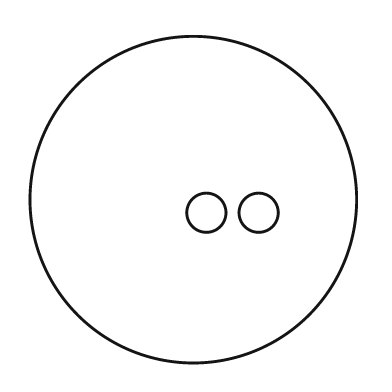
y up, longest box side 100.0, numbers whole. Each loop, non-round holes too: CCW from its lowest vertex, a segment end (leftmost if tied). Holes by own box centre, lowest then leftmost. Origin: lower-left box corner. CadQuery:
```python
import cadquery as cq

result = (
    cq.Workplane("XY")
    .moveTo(50.0, 50.0)
    .circle(50.0)
    .moveTo(54.0, 46.0)
    .circle(6.0)
    .moveTo(70.0, 46.0)
    .circle(6.0)
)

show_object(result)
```